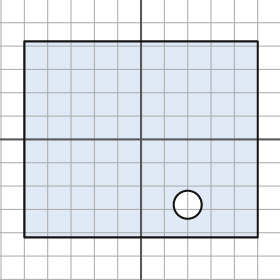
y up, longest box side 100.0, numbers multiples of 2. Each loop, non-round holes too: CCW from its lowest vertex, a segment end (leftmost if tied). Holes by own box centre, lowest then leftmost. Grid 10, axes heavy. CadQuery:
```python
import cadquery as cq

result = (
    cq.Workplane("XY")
    .moveTo(-50.0, -42.0)
    .lineTo(50.0, -42.0)
    .lineTo(50.0, 42.0)
    .lineTo(-50.0, 42.0)
    .close()
    .moveTo(20.0, -28.0)
    .circle(6.0)
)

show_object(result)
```